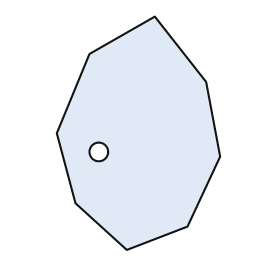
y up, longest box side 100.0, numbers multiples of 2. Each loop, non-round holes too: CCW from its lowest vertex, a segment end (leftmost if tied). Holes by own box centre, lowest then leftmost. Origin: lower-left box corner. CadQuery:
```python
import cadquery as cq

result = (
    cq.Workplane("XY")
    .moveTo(30.0, 0.0)
    .lineTo(56.0, 10.0)
    .lineTo(70.0, 40.0)
    .lineTo(64.0, 72.0)
    .lineTo(42.0, 100.0)
    .lineTo(14.0, 84.0)
    .lineTo(0.0, 50.0)
    .lineTo(8.0, 20.0)
    .close()
    .moveTo(18.0, 42.0)
    .circle(4.0)
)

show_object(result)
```